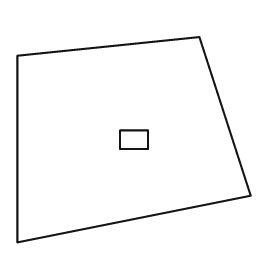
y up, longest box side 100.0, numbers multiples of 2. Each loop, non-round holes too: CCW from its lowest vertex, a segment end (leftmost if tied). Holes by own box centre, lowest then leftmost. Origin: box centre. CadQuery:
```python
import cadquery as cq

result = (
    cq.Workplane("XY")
    .moveTo(-50.0, -44.0)
    .lineTo(50.0, -24.0)
    .lineTo(28.0, 44.0)
    .lineTo(-50.0, 36.0)
    .close()
    .moveTo(-6.0, -4.0)
    .lineTo(6.0, -4.0)
    .lineTo(6.0, 4.0)
    .lineTo(-6.0, 4.0)
    .close()
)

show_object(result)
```